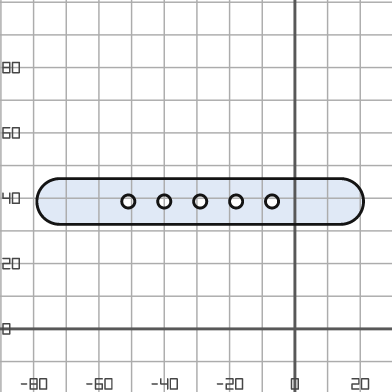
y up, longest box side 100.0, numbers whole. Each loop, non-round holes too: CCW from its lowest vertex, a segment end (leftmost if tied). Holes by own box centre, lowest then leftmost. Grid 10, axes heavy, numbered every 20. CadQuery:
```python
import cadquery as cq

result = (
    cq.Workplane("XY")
    .moveTo(-72.0, 32.0)
    .lineTo(14.0, 32.0)
    .threePointArc((21.0, 39.0), (14.0, 46.0))
    .lineTo(-72.0, 46.0)
    .threePointArc((-79.0, 39.0), (-72.0, 32.0))
    .close()
    .moveTo(-51.0, 39.0)
    .circle(2.0)
    .moveTo(-40.0, 39.0)
    .circle(2.0)
    .moveTo(-29.0, 39.0)
    .circle(2.0)
    .moveTo(-18.0, 39.0)
    .circle(2.0)
    .moveTo(-7.0, 39.0)
    .circle(2.0)
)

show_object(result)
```